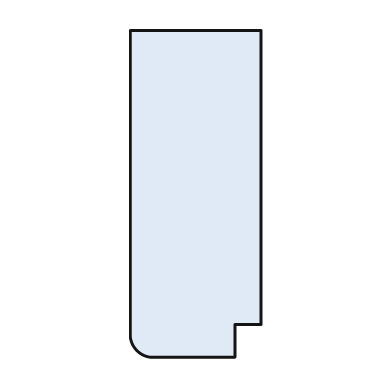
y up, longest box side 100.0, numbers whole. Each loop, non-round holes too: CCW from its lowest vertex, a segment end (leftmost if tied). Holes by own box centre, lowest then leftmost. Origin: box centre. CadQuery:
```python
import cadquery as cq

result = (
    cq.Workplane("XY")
    .moveTo(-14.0, -50.0)
    .lineTo(12.0, -50.0)
    .lineTo(12.0, -40.0)
    .lineTo(20.0, -40.0)
    .lineTo(20.0, 50.0)
    .lineTo(-20.0, 50.0)
    .lineTo(-20.0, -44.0)
    .threePointArc((-18.0, -48.0), (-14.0, -50.0))
    .close()
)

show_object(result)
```